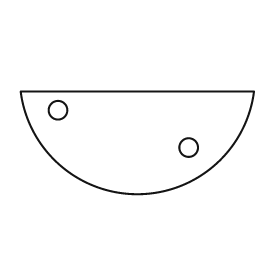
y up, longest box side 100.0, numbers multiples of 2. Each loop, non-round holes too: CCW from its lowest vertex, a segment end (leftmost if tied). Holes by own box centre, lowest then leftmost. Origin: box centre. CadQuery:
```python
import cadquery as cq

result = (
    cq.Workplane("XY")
    .moveTo(-50.0, 22.0)
    .threePointArc((0.0, -22.0), (50.0, 22.0))
    .close()
    .moveTo(22.0, -2.0)
    .circle(4.0)
    .moveTo(-34.0, 14.0)
    .circle(4.0)
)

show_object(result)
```